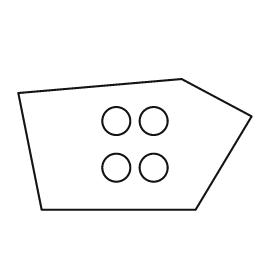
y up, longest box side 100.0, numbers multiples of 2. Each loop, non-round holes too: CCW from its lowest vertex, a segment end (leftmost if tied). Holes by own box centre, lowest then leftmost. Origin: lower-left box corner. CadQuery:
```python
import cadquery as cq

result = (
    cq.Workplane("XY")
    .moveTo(10.0, 0.0)
    .lineTo(76.0, 0.0)
    .lineTo(100.0, 40.0)
    .lineTo(70.0, 56.0)
    .lineTo(0.0, 50.0)
    .close()
    .moveTo(42.0, 18.0)
    .circle(6.0)
    .moveTo(58.0, 18.0)
    .circle(6.0)
    .moveTo(42.0, 38.0)
    .circle(6.0)
    .moveTo(58.0, 38.0)
    .circle(6.0)
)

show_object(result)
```